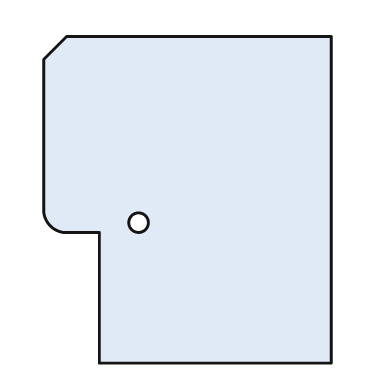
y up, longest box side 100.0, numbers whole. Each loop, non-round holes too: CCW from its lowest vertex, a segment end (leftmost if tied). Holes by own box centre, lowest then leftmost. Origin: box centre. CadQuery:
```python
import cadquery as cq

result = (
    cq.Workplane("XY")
    .moveTo(-27.0, -50.0)
    .lineTo(44.0, -50.0)
    .lineTo(44.0, 50.0)
    .lineTo(-37.0, 50.0)
    .lineTo(-44.0, 43.0)
    .lineTo(-44.0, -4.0)
    .threePointArc((-42.0, -8.0), (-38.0, -10.0))
    .lineTo(-27.0, -10.0)
    .close()
    .moveTo(-15.0, -7.0)
    .circle(3.0)
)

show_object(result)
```